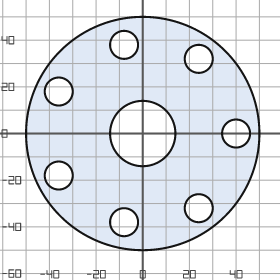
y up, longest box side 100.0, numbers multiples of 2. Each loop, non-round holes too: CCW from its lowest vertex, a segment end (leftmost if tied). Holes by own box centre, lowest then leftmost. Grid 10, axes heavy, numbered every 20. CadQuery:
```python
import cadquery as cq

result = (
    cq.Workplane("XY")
    .moveTo(0.0, 0.0)
    .circle(50.0)
    .moveTo(-8.0, -38.0)
    .circle(6.0)
    .moveTo(24.0, -32.0)
    .circle(6.0)
    .moveTo(-36.0, -18.0)
    .circle(6.0)
    .moveTo(0.0, 0.0)
    .circle(14.0)
    .moveTo(40.0, 0.0)
    .circle(6.0)
    .moveTo(-36.0, 18.0)
    .circle(6.0)
    .moveTo(24.0, 32.0)
    .circle(6.0)
    .moveTo(-8.0, 38.0)
    .circle(6.0)
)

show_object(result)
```